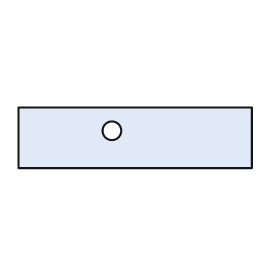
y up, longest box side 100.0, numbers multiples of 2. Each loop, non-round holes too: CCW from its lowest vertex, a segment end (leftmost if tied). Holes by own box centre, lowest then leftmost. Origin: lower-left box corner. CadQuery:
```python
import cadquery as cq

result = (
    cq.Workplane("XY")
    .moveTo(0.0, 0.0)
    .lineTo(100.0, 0.0)
    .lineTo(100.0, 26.0)
    .lineTo(0.0, 26.0)
    .close()
    .moveTo(40.0, 16.0)
    .circle(4.0)
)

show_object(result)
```